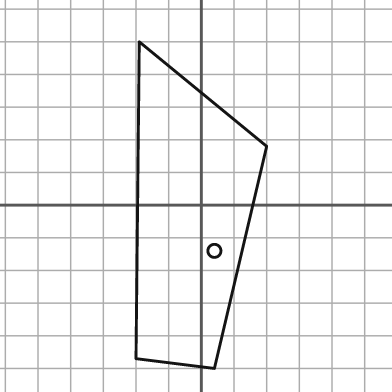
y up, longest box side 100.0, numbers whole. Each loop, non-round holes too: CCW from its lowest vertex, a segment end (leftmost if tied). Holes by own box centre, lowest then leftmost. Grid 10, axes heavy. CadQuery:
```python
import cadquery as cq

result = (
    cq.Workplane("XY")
    .moveTo(4.0, -50.0)
    .lineTo(20.0, 18.0)
    .lineTo(-19.0, 50.0)
    .lineTo(-20.0, -47.0)
    .close()
    .moveTo(4.0, -14.0)
    .circle(2.0)
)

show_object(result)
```